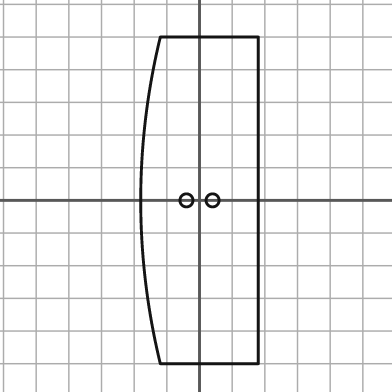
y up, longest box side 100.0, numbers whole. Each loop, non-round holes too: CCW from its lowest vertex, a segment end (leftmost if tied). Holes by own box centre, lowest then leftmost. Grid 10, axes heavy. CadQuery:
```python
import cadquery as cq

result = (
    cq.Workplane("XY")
    .moveTo(-12.0, -50.0)
    .lineTo(18.0, -50.0)
    .lineTo(18.0, 50.0)
    .lineTo(-12.0, 50.0)
    .threePointArc((-18.0, 0.0), (-12.0, -50.0))
    .close()
    .moveTo(-4.0, 0.0)
    .circle(2.0)
    .moveTo(4.0, 0.0)
    .circle(2.0)
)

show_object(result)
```